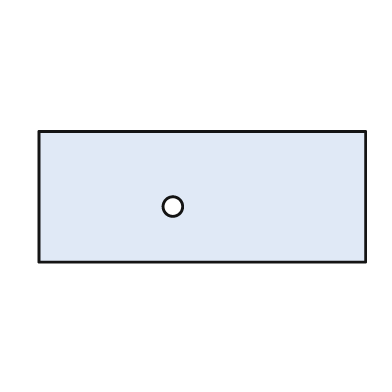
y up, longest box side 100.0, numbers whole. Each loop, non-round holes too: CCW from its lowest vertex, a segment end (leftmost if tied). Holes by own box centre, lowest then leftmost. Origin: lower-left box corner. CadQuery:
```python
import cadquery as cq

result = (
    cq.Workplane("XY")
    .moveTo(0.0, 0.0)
    .lineTo(100.0, 0.0)
    .lineTo(100.0, 40.0)
    .lineTo(0.0, 40.0)
    .close()
    .moveTo(41.0, 17.0)
    .circle(3.0)
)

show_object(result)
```